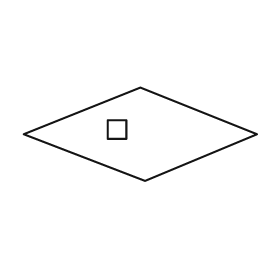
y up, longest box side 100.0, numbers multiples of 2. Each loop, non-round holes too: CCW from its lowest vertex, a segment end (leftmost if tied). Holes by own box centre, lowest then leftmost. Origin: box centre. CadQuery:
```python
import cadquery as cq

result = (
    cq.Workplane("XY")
    .moveTo(2.0, -20.0)
    .lineTo(50.0, 0.0)
    .lineTo(0.0, 20.0)
    .lineTo(-50.0, 0.0)
    .close()
    .moveTo(-14.0, -2.0)
    .lineTo(-6.0, -2.0)
    .lineTo(-6.0, 6.0)
    .lineTo(-14.0, 6.0)
    .close()
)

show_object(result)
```